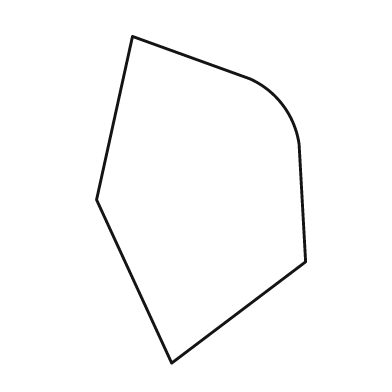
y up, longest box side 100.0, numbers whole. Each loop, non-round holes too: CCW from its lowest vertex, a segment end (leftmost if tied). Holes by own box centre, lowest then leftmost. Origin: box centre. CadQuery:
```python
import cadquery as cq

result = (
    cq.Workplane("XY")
    .moveTo(-9.0, -50.0)
    .lineTo(32.0, -19.0)
    .lineTo(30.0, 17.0)
    .threePointArc((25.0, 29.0), (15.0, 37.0))
    .lineTo(-21.0, 50.0)
    .lineTo(-32.0, 0.0)
    .close()
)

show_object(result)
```